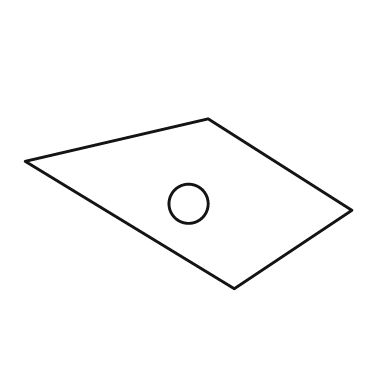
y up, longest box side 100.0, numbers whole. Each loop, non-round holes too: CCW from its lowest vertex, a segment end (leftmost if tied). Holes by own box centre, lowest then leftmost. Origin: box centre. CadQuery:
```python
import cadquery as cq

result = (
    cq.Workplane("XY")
    .moveTo(14.0, -26.0)
    .lineTo(50.0, -2.0)
    .lineTo(6.0, 26.0)
    .lineTo(-50.0, 13.0)
    .close()
    .moveTo(0.0, 0.0)
    .circle(6.0)
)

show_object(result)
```